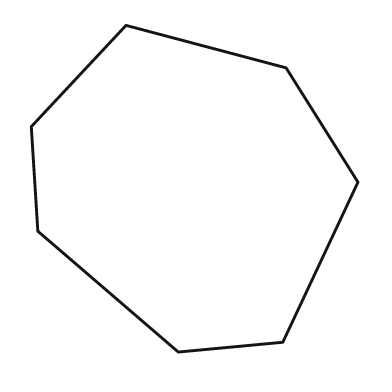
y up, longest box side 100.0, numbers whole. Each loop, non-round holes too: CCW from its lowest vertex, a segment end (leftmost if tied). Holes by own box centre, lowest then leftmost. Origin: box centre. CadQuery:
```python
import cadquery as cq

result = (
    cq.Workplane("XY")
    .moveTo(-5.0, -50.0)
    .lineTo(27.0, -47.0)
    .lineTo(50.0, 2.0)
    .lineTo(28.0, 37.0)
    .lineTo(-21.0, 50.0)
    .lineTo(-50.0, 19.0)
    .lineTo(-48.0, -13.0)
    .close()
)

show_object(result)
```